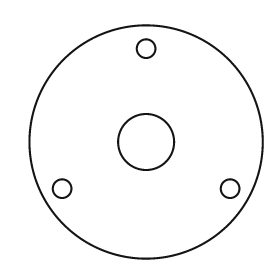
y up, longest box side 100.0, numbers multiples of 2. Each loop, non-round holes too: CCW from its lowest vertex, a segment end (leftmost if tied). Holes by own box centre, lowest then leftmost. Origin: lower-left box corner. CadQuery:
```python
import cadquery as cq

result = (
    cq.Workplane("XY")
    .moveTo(50.0, 50.0)
    .circle(50.0)
    .moveTo(14.0, 30.0)
    .circle(4.0)
    .moveTo(86.0, 30.0)
    .circle(4.0)
    .moveTo(50.0, 50.0)
    .circle(12.0)
    .moveTo(50.0, 90.0)
    .circle(4.0)
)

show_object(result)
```